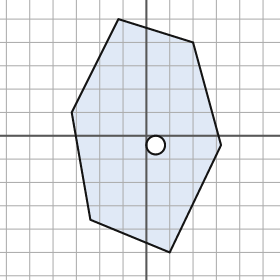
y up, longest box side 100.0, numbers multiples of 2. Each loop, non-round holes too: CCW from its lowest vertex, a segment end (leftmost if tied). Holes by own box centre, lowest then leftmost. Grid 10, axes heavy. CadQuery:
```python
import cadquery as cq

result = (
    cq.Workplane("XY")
    .moveTo(10.0, -50.0)
    .lineTo(32.0, -4.0)
    .lineTo(20.0, 40.0)
    .lineTo(-12.0, 50.0)
    .lineTo(-32.0, 10.0)
    .lineTo(-24.0, -36.0)
    .close()
    .moveTo(4.0, -4.0)
    .circle(4.0)
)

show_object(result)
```